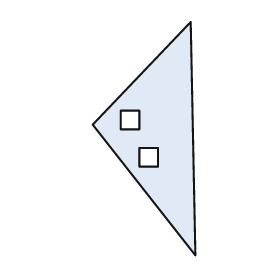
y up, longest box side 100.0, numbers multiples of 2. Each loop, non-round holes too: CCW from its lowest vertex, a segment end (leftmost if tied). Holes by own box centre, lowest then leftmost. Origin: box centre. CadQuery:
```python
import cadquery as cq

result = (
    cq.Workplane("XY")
    .moveTo(22.0, -50.0)
    .lineTo(20.0, 50.0)
    .lineTo(-22.0, 6.0)
    .close()
    .moveTo(-2.0, -12.0)
    .lineTo(6.0, -12.0)
    .lineTo(6.0, -4.0)
    .lineTo(-2.0, -4.0)
    .close()
    .moveTo(-10.0, 4.0)
    .lineTo(-2.0, 4.0)
    .lineTo(-2.0, 12.0)
    .lineTo(-10.0, 12.0)
    .close()
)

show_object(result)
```